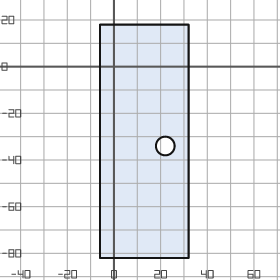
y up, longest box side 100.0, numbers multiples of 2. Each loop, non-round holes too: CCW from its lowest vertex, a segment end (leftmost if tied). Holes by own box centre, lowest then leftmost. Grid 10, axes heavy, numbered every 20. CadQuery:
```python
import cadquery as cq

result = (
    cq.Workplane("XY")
    .moveTo(-6.0, -82.0)
    .lineTo(32.0, -82.0)
    .lineTo(32.0, 18.0)
    .lineTo(-6.0, 18.0)
    .close()
    .moveTo(22.0, -34.0)
    .circle(4.0)
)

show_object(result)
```